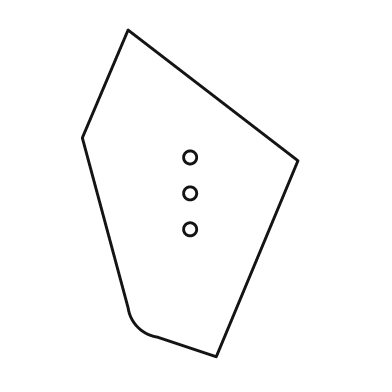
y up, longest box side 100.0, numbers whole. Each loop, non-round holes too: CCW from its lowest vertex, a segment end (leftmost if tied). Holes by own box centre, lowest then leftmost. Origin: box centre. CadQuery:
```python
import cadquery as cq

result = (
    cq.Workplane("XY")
    .moveTo(8.0, -50.0)
    .lineTo(33.0, 10.0)
    .lineTo(-19.0, 50.0)
    .lineTo(-33.0, 17.0)
    .lineTo(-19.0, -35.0)
    .threePointArc((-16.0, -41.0), (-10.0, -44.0))
    .close()
    .moveTo(0.0, -11.0)
    .circle(2.0)
    .moveTo(0.0, 0.0)
    .circle(2.0)
    .moveTo(0.0, 11.0)
    .circle(2.0)
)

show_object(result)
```